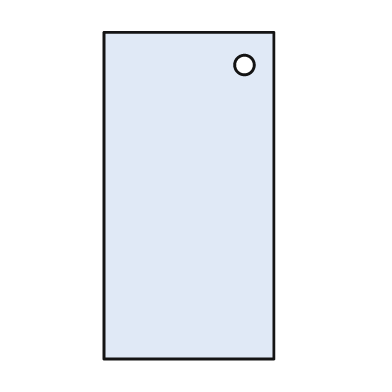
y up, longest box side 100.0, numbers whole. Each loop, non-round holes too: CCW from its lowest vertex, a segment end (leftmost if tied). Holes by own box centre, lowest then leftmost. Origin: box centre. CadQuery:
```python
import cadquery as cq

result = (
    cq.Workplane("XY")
    .moveTo(-26.0, -50.0)
    .lineTo(26.0, -50.0)
    .lineTo(26.0, 50.0)
    .lineTo(-26.0, 50.0)
    .close()
    .moveTo(17.0, 40.0)
    .circle(3.0)
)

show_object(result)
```